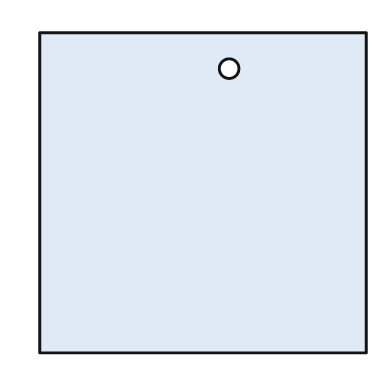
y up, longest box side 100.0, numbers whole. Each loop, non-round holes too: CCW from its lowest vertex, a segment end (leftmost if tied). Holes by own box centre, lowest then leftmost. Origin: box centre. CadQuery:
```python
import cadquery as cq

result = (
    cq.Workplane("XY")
    .moveTo(-50.0, -49.0)
    .lineTo(50.0, -49.0)
    .lineTo(50.0, 49.0)
    .lineTo(-50.0, 49.0)
    .close()
    .moveTo(8.0, 38.0)
    .circle(3.0)
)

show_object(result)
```